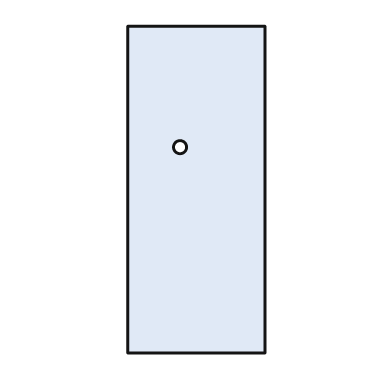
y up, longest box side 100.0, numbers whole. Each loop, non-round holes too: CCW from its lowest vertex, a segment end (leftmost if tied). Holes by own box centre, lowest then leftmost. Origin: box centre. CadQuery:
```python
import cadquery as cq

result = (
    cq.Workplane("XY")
    .moveTo(-21.0, -50.0)
    .lineTo(21.0, -50.0)
    .lineTo(21.0, 50.0)
    .lineTo(-21.0, 50.0)
    .close()
    .moveTo(-5.0, 13.0)
    .circle(2.0)
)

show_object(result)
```